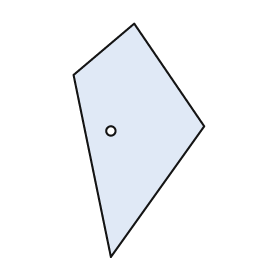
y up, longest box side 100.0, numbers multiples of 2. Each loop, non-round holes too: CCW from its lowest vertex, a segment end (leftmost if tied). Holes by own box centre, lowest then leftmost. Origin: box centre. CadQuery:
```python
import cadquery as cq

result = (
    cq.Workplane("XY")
    .moveTo(-12.0, -50.0)
    .lineTo(28.0, 6.0)
    .lineTo(-2.0, 50.0)
    .lineTo(-28.0, 28.0)
    .close()
    .moveTo(-12.0, 4.0)
    .circle(2.0)
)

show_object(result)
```